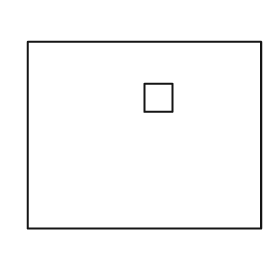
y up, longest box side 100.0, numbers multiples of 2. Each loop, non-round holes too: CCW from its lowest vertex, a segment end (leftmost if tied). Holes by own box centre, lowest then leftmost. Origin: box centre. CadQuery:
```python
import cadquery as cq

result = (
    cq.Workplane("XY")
    .moveTo(-50.0, -40.0)
    .lineTo(50.0, -40.0)
    .lineTo(50.0, 40.0)
    .lineTo(-50.0, 40.0)
    .close()
    .moveTo(0.0, 10.0)
    .lineTo(12.0, 10.0)
    .lineTo(12.0, 22.0)
    .lineTo(0.0, 22.0)
    .close()
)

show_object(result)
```